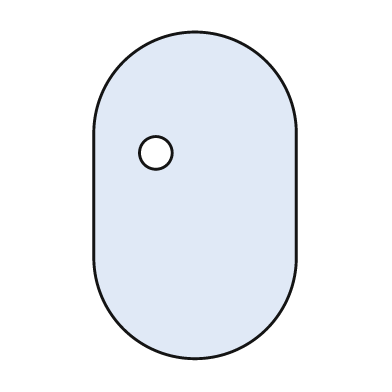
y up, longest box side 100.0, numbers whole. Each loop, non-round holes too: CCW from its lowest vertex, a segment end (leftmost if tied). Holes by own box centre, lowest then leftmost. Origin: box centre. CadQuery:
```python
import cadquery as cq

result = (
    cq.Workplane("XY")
    .moveTo(-31.0, -19.0)
    .threePointArc((0.0, -50.0), (31.0, -19.0))
    .lineTo(31.0, 19.0)
    .threePointArc((0.0, 50.0), (-31.0, 19.0))
    .close()
    .moveTo(-12.0, 13.0)
    .circle(5.0)
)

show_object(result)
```